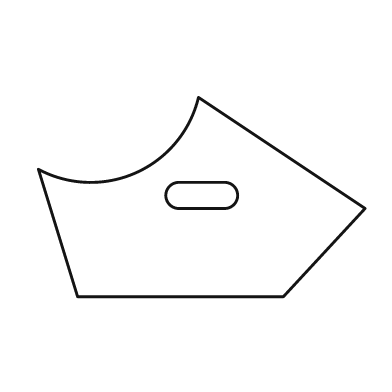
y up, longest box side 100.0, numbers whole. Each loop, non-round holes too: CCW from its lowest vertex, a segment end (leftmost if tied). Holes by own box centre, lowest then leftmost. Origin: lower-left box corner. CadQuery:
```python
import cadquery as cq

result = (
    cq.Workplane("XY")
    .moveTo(12.0, 0.0)
    .lineTo(75.0, 0.0)
    .lineTo(100.0, 27.0)
    .lineTo(49.0, 61.0)
    .threePointArc((30.0, 38.0), (0.0, 39.0))
    .close()
    .moveTo(43.0, 27.0)
    .lineTo(57.0, 27.0)
    .threePointArc((61.0, 31.0), (57.0, 35.0))
    .lineTo(43.0, 35.0)
    .threePointArc((39.0, 31.0), (43.0, 27.0))
    .close()
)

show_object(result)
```